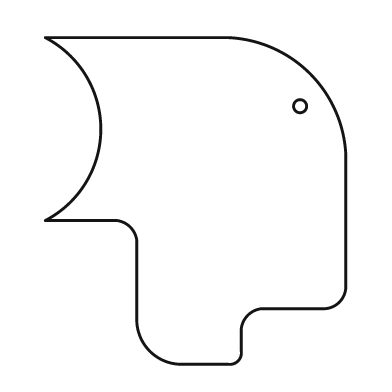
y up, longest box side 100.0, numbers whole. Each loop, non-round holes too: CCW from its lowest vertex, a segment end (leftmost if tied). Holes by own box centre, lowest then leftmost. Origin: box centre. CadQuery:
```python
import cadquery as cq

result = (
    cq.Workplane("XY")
    .moveTo(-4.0, -50.0)
    .lineTo(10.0, -50.0)
    .threePointArc((13.0, -49.0), (14.0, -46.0))
    .lineTo(14.0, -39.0)
    .threePointArc((16.0, -35.0), (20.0, -33.0))
    .lineTo(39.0, -33.0)
    .threePointArc((44.0, -31.0), (46.0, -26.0))
    .lineTo(46.0, 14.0)
    .threePointArc((35.0, 39.0), (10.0, 50.0))
    .lineTo(-46.0, 50.0)
    .threePointArc((-29.0, 22.0), (-46.0, -6.0))
    .lineTo(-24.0, -6.0)
    .threePointArc((-20.0, -8.0), (-18.0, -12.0))
    .lineTo(-18.0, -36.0)
    .threePointArc((-14.0, -46.0), (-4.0, -50.0))
    .close()
    .moveTo(32.0, 29.0)
    .circle(2.0)
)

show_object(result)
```